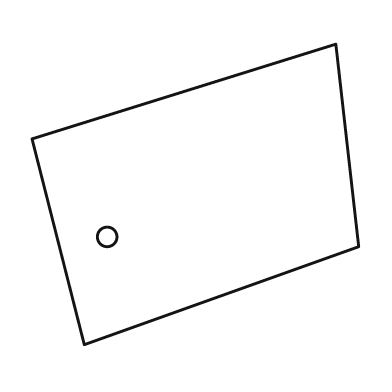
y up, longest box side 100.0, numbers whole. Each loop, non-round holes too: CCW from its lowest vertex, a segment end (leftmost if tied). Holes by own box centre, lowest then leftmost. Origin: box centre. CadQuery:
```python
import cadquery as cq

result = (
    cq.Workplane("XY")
    .moveTo(-34.0, -46.0)
    .lineTo(50.0, -16.0)
    .lineTo(43.0, 46.0)
    .lineTo(-50.0, 17.0)
    .close()
    .moveTo(-27.0, -13.0)
    .circle(3.0)
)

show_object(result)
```